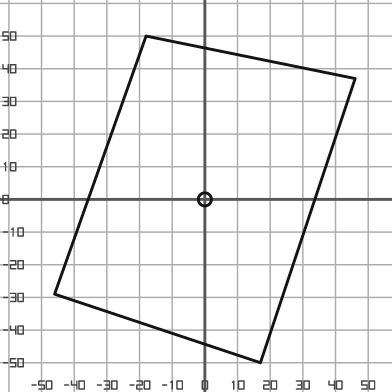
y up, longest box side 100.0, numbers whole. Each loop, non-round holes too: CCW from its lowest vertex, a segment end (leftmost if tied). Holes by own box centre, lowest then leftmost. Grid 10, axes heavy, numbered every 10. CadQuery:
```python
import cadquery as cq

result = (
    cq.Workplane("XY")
    .moveTo(17.0, -50.0)
    .lineTo(46.0, 37.0)
    .lineTo(-18.0, 50.0)
    .lineTo(-46.0, -29.0)
    .close()
    .moveTo(0.0, 0.0)
    .circle(2.0)
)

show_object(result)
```